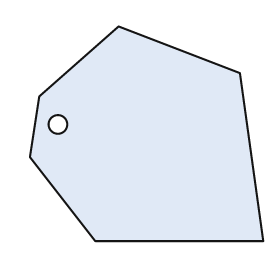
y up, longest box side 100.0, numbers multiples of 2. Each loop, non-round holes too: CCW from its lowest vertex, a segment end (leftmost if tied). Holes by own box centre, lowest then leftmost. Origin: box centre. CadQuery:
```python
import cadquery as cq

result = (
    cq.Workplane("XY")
    .moveTo(-22.0, -46.0)
    .lineTo(50.0, -46.0)
    .lineTo(40.0, 26.0)
    .lineTo(-12.0, 46.0)
    .lineTo(-46.0, 16.0)
    .lineTo(-50.0, -10.0)
    .close()
    .moveTo(-38.0, 4.0)
    .circle(4.0)
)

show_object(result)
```